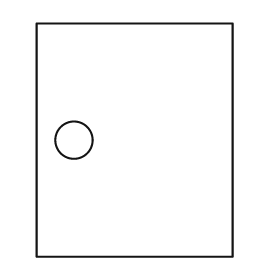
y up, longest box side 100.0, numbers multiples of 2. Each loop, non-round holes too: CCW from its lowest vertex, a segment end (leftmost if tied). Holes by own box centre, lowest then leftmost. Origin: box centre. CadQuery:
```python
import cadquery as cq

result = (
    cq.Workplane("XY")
    .moveTo(-42.0, -50.0)
    .lineTo(42.0, -50.0)
    .lineTo(42.0, 50.0)
    .lineTo(-42.0, 50.0)
    .close()
    .moveTo(-26.0, 0.0)
    .circle(8.0)
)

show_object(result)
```